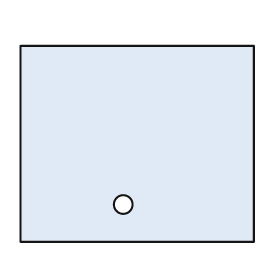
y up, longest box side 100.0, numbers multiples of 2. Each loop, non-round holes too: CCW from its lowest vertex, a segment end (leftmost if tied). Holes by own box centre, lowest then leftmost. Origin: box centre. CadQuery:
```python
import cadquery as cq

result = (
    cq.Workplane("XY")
    .moveTo(-50.0, -42.0)
    .lineTo(50.0, -42.0)
    .lineTo(50.0, 42.0)
    .lineTo(-50.0, 42.0)
    .close()
    .moveTo(-6.0, -26.0)
    .circle(4.0)
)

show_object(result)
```